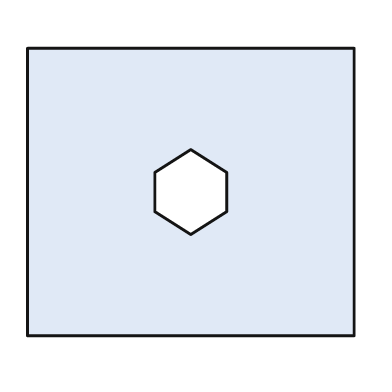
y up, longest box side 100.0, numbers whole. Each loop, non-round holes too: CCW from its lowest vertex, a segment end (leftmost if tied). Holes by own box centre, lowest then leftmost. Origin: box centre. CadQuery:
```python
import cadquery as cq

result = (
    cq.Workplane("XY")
    .moveTo(-50.0, -44.0)
    .lineTo(50.0, -44.0)
    .lineTo(50.0, 44.0)
    .lineTo(-50.0, 44.0)
    .close()
    .moveTo(0.0, -13.0)
    .lineTo(11.0, -6.0)
    .lineTo(11.0, 6.0)
    .lineTo(0.0, 13.0)
    .lineTo(-11.0, 6.0)
    .lineTo(-11.0, -6.0)
    .close()
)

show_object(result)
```